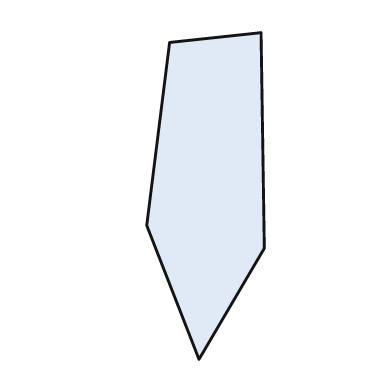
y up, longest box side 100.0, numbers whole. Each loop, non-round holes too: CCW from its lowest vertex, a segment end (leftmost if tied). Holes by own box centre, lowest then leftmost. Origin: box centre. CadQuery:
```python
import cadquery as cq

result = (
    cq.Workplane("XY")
    .moveTo(-2.0, -50.0)
    .lineTo(18.0, -16.0)
    .lineTo(17.0, 50.0)
    .lineTo(-11.0, 47.0)
    .lineTo(-18.0, -9.0)
    .close()
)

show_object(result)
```